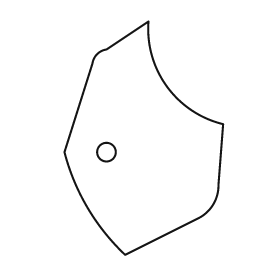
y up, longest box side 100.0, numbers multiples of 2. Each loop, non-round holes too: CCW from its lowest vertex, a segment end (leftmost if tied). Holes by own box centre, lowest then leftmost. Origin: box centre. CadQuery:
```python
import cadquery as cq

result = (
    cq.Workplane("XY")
    .moveTo(-8.0, -50.0)
    .lineTo(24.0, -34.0)
    .threePointArc((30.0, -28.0), (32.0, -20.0))
    .lineTo(34.0, 6.0)
    .threePointArc((10.0, 22.0), (2.0, 50.0))
    .lineTo(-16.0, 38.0)
    .threePointArc((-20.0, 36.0), (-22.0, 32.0))
    .lineTo(-34.0, -6.0)
    .threePointArc((-24.0, -30.0), (-8.0, -50.0))
    .close()
    .moveTo(-16.0, -6.0)
    .circle(4.0)
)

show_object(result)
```